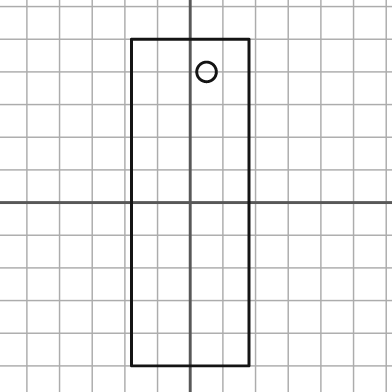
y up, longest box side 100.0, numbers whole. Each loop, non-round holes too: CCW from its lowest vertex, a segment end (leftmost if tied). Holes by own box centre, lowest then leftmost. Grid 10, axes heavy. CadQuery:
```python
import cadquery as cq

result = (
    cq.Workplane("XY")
    .moveTo(-18.0, -50.0)
    .lineTo(18.0, -50.0)
    .lineTo(18.0, 50.0)
    .lineTo(-18.0, 50.0)
    .close()
    .moveTo(5.0, 40.0)
    .circle(3.0)
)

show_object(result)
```